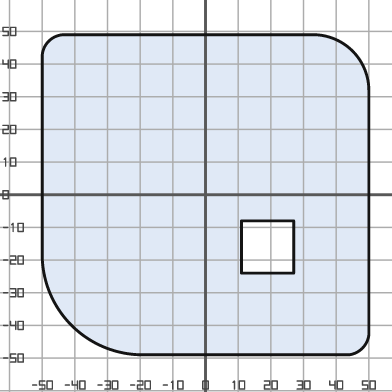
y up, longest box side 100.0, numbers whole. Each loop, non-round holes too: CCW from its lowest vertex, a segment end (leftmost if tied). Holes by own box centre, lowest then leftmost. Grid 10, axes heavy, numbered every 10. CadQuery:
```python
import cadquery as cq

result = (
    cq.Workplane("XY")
    .moveTo(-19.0, -49.0)
    .lineTo(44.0, -49.0)
    .threePointArc((48.0, -47.0), (50.0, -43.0))
    .lineTo(50.0, 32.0)
    .threePointArc((45.0, 44.0), (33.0, 49.0))
    .lineTo(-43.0, 49.0)
    .threePointArc((-48.0, 47.0), (-50.0, 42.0))
    .lineTo(-50.0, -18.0)
    .threePointArc((-41.0, -40.0), (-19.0, -49.0))
    .close()
    .moveTo(11.0, -24.0)
    .lineTo(27.0, -24.0)
    .lineTo(27.0, -8.0)
    .lineTo(11.0, -8.0)
    .close()
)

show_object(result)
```